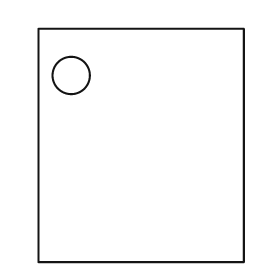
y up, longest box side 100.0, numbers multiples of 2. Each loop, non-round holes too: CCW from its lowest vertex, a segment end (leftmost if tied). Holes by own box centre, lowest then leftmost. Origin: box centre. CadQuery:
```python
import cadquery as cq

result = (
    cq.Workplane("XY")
    .moveTo(-44.0, -50.0)
    .lineTo(44.0, -50.0)
    .lineTo(44.0, 50.0)
    .lineTo(-44.0, 50.0)
    .close()
    .moveTo(-30.0, 30.0)
    .circle(8.0)
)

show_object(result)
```